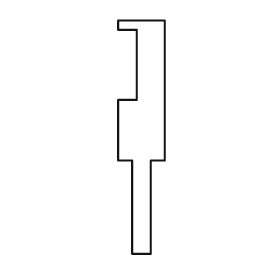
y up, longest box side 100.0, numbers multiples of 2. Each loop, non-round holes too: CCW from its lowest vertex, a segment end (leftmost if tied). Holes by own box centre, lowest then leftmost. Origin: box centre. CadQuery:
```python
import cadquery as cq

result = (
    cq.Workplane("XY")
    .moveTo(-4.0, -50.0)
    .lineTo(4.0, -50.0)
    .lineTo(4.0, -10.0)
    .lineTo(10.0, -10.0)
    .lineTo(10.0, 50.0)
    .lineTo(-10.0, 50.0)
    .lineTo(-10.0, 46.0)
    .lineTo(-2.0, 46.0)
    .lineTo(-2.0, 16.0)
    .lineTo(-10.0, 16.0)
    .lineTo(-10.0, -10.0)
    .lineTo(-4.0, -10.0)
    .close()
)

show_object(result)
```